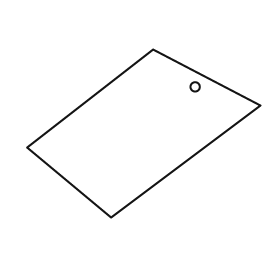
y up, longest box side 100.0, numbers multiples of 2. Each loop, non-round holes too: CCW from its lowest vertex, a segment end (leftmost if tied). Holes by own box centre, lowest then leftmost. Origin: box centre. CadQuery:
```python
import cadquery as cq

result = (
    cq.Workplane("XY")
    .moveTo(-14.0, -36.0)
    .lineTo(50.0, 12.0)
    .lineTo(4.0, 36.0)
    .lineTo(-50.0, -6.0)
    .close()
    .moveTo(22.0, 20.0)
    .circle(2.0)
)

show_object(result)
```